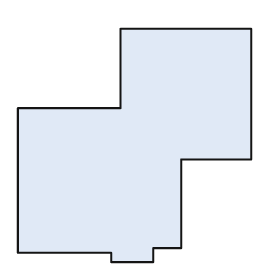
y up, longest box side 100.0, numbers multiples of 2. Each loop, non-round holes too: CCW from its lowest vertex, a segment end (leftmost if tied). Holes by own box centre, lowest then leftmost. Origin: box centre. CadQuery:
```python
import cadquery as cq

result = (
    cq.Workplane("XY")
    .moveTo(-10.0, -50.0)
    .lineTo(8.0, -50.0)
    .lineTo(8.0, -44.0)
    .lineTo(20.0, -44.0)
    .lineTo(20.0, -6.0)
    .lineTo(50.0, -6.0)
    .lineTo(50.0, 50.0)
    .lineTo(-6.0, 50.0)
    .lineTo(-6.0, 16.0)
    .lineTo(-50.0, 16.0)
    .lineTo(-50.0, -46.0)
    .lineTo(-10.0, -46.0)
    .close()
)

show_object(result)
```